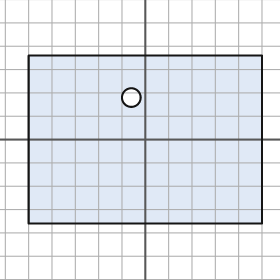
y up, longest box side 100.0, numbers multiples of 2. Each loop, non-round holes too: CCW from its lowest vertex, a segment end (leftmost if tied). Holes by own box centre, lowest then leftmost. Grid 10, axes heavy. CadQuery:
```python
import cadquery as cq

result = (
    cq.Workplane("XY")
    .moveTo(-50.0, -36.0)
    .lineTo(50.0, -36.0)
    .lineTo(50.0, 36.0)
    .lineTo(-50.0, 36.0)
    .close()
    .moveTo(-6.0, 18.0)
    .circle(4.0)
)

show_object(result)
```